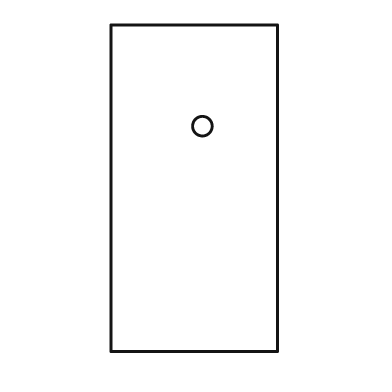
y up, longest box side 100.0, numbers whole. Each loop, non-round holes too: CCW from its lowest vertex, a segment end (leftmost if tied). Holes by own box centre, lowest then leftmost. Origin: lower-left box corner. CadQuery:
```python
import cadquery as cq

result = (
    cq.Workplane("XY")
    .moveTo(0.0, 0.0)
    .lineTo(51.0, 0.0)
    .lineTo(51.0, 100.0)
    .lineTo(0.0, 100.0)
    .close()
    .moveTo(28.0, 69.0)
    .circle(3.0)
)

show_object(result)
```